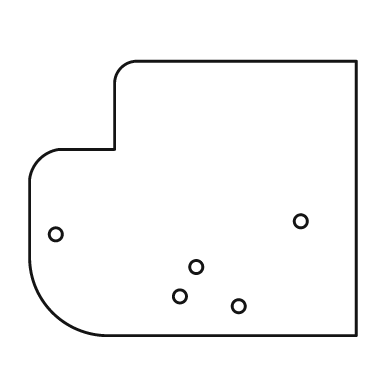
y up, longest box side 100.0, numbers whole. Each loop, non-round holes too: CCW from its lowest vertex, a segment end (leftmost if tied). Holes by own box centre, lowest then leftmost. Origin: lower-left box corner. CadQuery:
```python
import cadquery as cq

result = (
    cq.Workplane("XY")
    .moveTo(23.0, 0.0)
    .lineTo(100.0, 0.0)
    .lineTo(100.0, 84.0)
    .lineTo(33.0, 84.0)
    .threePointArc((28.0, 82.0), (26.0, 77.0))
    .lineTo(26.0, 57.0)
    .lineTo(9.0, 57.0)
    .threePointArc((3.0, 54.0), (0.0, 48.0))
    .lineTo(0.0, 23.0)
    .threePointArc((7.0, 7.0), (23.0, 0.0))
    .close()
    .moveTo(64.0, 9.0)
    .circle(2.0)
    .moveTo(46.0, 12.0)
    .circle(2.0)
    .moveTo(51.0, 21.0)
    .circle(2.0)
    .moveTo(8.0, 31.0)
    .circle(2.0)
    .moveTo(83.0, 35.0)
    .circle(2.0)
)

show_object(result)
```